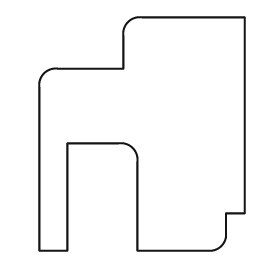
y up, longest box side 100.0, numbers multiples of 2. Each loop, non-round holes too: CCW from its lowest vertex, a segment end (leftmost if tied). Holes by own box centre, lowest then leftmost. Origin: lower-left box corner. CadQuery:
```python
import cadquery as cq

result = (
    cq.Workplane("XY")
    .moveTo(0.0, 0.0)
    .lineTo(12.0, 0.0)
    .lineTo(12.0, 46.0)
    .lineTo(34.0, 46.0)
    .threePointArc((40.0, 44.0), (42.0, 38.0))
    .lineTo(42.0, 0.0)
    .lineTo(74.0, 0.0)
    .threePointArc((78.0, 2.0), (80.0, 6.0))
    .lineTo(80.0, 16.0)
    .lineTo(88.0, 16.0)
    .lineTo(88.0, 100.0)
    .lineTo(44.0, 100.0)
    .threePointArc((38.0, 98.0), (36.0, 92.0))
    .lineTo(36.0, 78.0)
    .lineTo(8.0, 78.0)
    .threePointArc((2.0, 76.0), (0.0, 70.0))
    .close()
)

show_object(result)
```